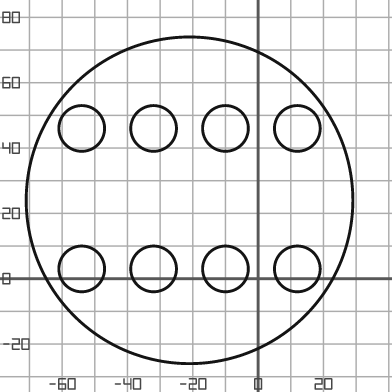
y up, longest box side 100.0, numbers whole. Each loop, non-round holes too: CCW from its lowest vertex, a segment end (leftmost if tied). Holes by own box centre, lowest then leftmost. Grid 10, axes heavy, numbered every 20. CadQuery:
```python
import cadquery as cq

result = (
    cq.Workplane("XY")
    .moveTo(-21.0, 24.0)
    .circle(50.0)
    .moveTo(-54.0, 3.0)
    .circle(7.0)
    .moveTo(-32.0, 3.0)
    .circle(7.0)
    .moveTo(-10.0, 3.0)
    .circle(7.0)
    .moveTo(12.0, 3.0)
    .circle(7.0)
    .moveTo(-54.0, 46.0)
    .circle(7.0)
    .moveTo(-32.0, 46.0)
    .circle(7.0)
    .moveTo(-10.0, 46.0)
    .circle(7.0)
    .moveTo(12.0, 46.0)
    .circle(7.0)
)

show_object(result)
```